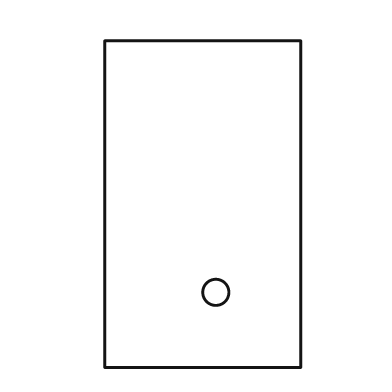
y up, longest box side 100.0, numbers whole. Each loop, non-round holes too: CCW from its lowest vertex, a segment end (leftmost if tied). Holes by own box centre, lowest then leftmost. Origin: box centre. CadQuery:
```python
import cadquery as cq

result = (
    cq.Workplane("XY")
    .moveTo(-30.0, -50.0)
    .lineTo(30.0, -50.0)
    .lineTo(30.0, 50.0)
    .lineTo(-30.0, 50.0)
    .close()
    .moveTo(4.0, -27.0)
    .circle(4.0)
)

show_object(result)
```